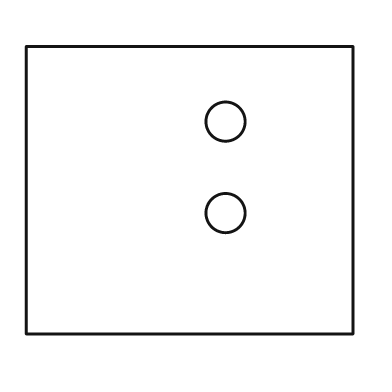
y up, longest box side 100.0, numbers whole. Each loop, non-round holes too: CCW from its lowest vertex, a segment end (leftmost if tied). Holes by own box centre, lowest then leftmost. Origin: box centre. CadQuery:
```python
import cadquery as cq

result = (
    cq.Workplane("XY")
    .moveTo(-50.0, -44.0)
    .lineTo(50.0, -44.0)
    .lineTo(50.0, 44.0)
    .lineTo(-50.0, 44.0)
    .close()
    .moveTo(11.0, -7.0)
    .circle(6.0)
    .moveTo(11.0, 21.0)
    .circle(6.0)
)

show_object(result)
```